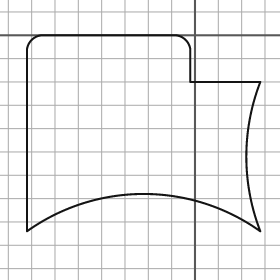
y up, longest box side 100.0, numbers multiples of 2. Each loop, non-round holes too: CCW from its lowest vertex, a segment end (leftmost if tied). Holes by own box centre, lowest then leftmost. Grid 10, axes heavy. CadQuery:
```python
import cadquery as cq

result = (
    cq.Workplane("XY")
    .moveTo(-72.0, -84.0)
    .threePointArc((-22.0, -68.0), (28.0, -84.0))
    .threePointArc((22.0, -52.0), (28.0, -20.0))
    .lineTo(-2.0, -20.0)
    .lineTo(-2.0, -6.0)
    .threePointArc((-4.0, -2.0), (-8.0, 0.0))
    .lineTo(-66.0, 0.0)
    .threePointArc((-70.0, -2.0), (-72.0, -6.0))
    .close()
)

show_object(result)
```